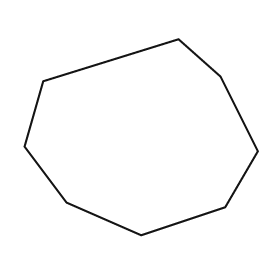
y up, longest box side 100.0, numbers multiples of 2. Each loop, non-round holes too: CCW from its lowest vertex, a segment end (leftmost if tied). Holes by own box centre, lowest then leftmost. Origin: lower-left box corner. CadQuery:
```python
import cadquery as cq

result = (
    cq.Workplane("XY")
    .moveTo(50.0, 0.0)
    .lineTo(86.0, 12.0)
    .lineTo(100.0, 36.0)
    .lineTo(84.0, 68.0)
    .lineTo(66.0, 84.0)
    .lineTo(8.0, 66.0)
    .lineTo(0.0, 38.0)
    .lineTo(18.0, 14.0)
    .close()
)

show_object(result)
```